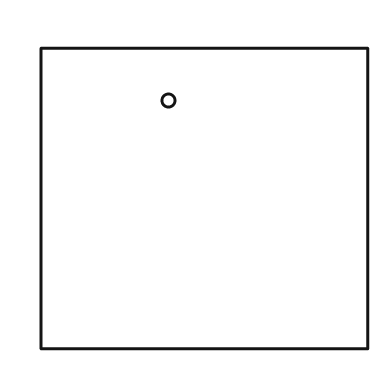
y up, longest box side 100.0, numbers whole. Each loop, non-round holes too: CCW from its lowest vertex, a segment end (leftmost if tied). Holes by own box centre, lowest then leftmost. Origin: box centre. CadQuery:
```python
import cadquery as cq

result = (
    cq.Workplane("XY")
    .moveTo(-50.0, -46.0)
    .lineTo(50.0, -46.0)
    .lineTo(50.0, 46.0)
    .lineTo(-50.0, 46.0)
    .close()
    .moveTo(-11.0, 30.0)
    .circle(2.0)
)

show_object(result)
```